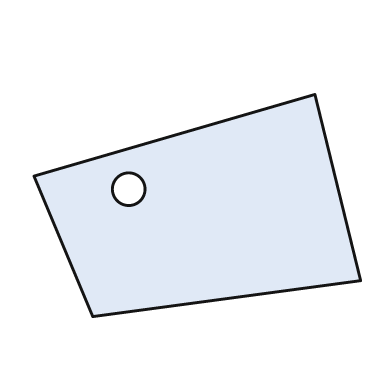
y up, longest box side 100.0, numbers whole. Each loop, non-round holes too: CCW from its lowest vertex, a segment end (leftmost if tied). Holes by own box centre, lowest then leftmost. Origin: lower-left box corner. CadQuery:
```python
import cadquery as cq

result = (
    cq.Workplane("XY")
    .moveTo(18.0, 0.0)
    .lineTo(100.0, 11.0)
    .lineTo(86.0, 68.0)
    .lineTo(0.0, 43.0)
    .close()
    .moveTo(29.0, 39.0)
    .circle(5.0)
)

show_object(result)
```